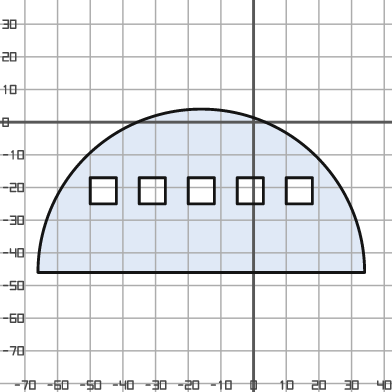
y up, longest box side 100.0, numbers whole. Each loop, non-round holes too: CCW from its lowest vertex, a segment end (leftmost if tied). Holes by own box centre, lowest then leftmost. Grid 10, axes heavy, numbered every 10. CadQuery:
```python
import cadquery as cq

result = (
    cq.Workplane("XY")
    .moveTo(-66.0, -46.0)
    .lineTo(34.0, -46.0)
    .threePointArc((-16.0, 4.0), (-66.0, -46.0))
    .close()
    .moveTo(-50.0, -25.0)
    .lineTo(-42.0, -25.0)
    .lineTo(-42.0, -17.0)
    .lineTo(-50.0, -17.0)
    .close()
    .moveTo(-35.0, -25.0)
    .lineTo(-27.0, -25.0)
    .lineTo(-27.0, -17.0)
    .lineTo(-35.0, -17.0)
    .close()
    .moveTo(-20.0, -25.0)
    .lineTo(-12.0, -25.0)
    .lineTo(-12.0, -17.0)
    .lineTo(-20.0, -17.0)
    .close()
    .moveTo(-5.0, -25.0)
    .lineTo(3.0, -25.0)
    .lineTo(3.0, -17.0)
    .lineTo(-5.0, -17.0)
    .close()
    .moveTo(10.0, -25.0)
    .lineTo(18.0, -25.0)
    .lineTo(18.0, -17.0)
    .lineTo(10.0, -17.0)
    .close()
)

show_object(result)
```